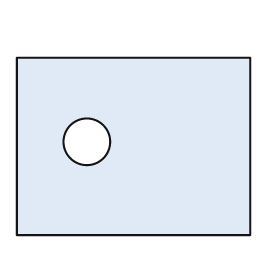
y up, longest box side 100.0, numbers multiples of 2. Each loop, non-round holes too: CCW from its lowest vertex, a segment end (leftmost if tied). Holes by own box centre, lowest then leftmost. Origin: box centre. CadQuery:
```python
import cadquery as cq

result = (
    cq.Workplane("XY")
    .moveTo(-50.0, -38.0)
    .lineTo(50.0, -38.0)
    .lineTo(50.0, 38.0)
    .lineTo(-50.0, 38.0)
    .close()
    .moveTo(-20.0, 2.0)
    .circle(10.0)
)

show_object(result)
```